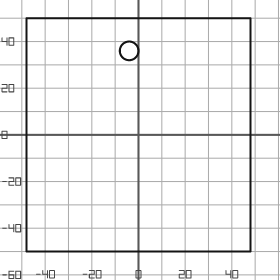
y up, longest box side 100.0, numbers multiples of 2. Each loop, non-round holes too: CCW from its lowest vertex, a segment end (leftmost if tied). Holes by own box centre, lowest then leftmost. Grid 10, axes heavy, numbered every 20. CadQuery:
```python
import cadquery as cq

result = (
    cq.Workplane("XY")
    .moveTo(-48.0, -50.0)
    .lineTo(48.0, -50.0)
    .lineTo(48.0, 50.0)
    .lineTo(-48.0, 50.0)
    .close()
    .moveTo(-4.0, 36.0)
    .circle(4.0)
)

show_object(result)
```